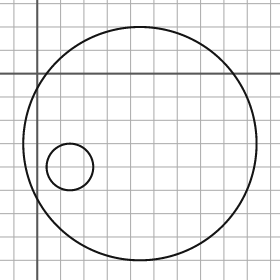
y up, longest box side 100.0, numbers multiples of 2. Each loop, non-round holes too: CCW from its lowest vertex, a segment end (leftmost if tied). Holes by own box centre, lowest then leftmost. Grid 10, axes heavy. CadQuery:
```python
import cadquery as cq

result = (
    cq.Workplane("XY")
    .moveTo(44.0, -30.0)
    .circle(50.0)
    .moveTo(14.0, -40.0)
    .circle(10.0)
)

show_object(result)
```